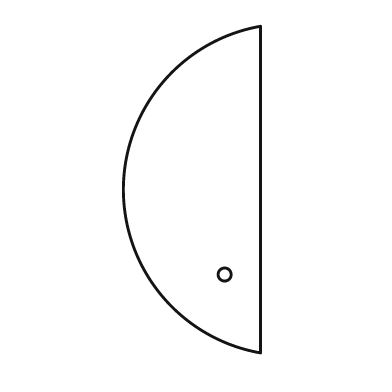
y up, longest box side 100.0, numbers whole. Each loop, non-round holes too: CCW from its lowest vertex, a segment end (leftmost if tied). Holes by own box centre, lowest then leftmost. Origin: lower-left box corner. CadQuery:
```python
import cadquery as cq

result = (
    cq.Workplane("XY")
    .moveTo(42.0, 0.0)
    .lineTo(42.0, 100.0)
    .threePointArc((0.0, 50.0), (42.0, 0.0))
    .close()
    .moveTo(31.0, 24.0)
    .circle(2.0)
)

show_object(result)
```